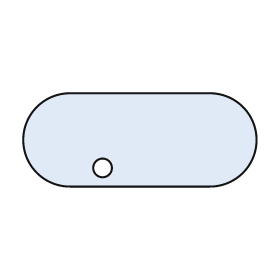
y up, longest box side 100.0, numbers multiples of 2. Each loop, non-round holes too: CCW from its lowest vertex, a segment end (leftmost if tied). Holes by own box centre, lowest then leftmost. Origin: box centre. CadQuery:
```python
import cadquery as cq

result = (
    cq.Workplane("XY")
    .moveTo(-30.0, -20.0)
    .lineTo(30.0, -20.0)
    .threePointArc((50.0, 0.0), (30.0, 20.0))
    .lineTo(-30.0, 20.0)
    .threePointArc((-50.0, 0.0), (-30.0, -20.0))
    .close()
    .moveTo(-16.0, -12.0)
    .circle(4.0)
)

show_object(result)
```